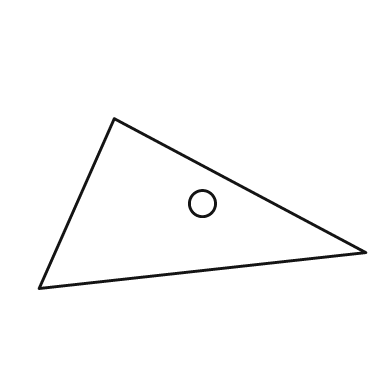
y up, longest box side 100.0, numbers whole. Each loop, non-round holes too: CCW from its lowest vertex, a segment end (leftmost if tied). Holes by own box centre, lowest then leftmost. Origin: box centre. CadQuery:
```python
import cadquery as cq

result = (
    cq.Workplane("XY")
    .moveTo(-50.0, -26.0)
    .lineTo(50.0, -15.0)
    .lineTo(-27.0, 26.0)
    .close()
    .moveTo(0.0, 0.0)
    .circle(4.0)
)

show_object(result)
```